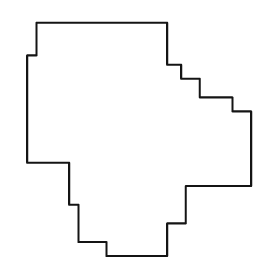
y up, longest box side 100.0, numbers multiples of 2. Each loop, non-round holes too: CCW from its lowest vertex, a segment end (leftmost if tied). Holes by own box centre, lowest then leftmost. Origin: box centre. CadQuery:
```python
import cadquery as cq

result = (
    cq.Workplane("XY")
    .moveTo(-14.0, -50.0)
    .lineTo(12.0, -50.0)
    .lineTo(12.0, -36.0)
    .lineTo(20.0, -36.0)
    .lineTo(20.0, -20.0)
    .lineTo(48.0, -20.0)
    .lineTo(48.0, 12.0)
    .lineTo(40.0, 12.0)
    .lineTo(40.0, 18.0)
    .lineTo(26.0, 18.0)
    .lineTo(26.0, 26.0)
    .lineTo(18.0, 26.0)
    .lineTo(18.0, 32.0)
    .lineTo(12.0, 32.0)
    .lineTo(12.0, 50.0)
    .lineTo(-44.0, 50.0)
    .lineTo(-44.0, 36.0)
    .lineTo(-48.0, 36.0)
    .lineTo(-48.0, -10.0)
    .lineTo(-30.0, -10.0)
    .lineTo(-30.0, -28.0)
    .lineTo(-26.0, -28.0)
    .lineTo(-26.0, -44.0)
    .lineTo(-14.0, -44.0)
    .close()
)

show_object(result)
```